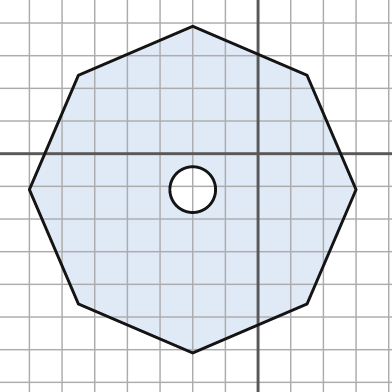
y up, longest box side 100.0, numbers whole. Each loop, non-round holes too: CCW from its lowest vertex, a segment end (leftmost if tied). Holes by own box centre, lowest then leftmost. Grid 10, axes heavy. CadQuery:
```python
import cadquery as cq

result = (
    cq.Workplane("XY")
    .moveTo(-20.0, -61.0)
    .lineTo(15.0, -46.0)
    .lineTo(30.0, -11.0)
    .lineTo(15.0, 24.0)
    .lineTo(-20.0, 39.0)
    .lineTo(-55.0, 24.0)
    .lineTo(-70.0, -11.0)
    .lineTo(-55.0, -46.0)
    .close()
    .moveTo(-20.0, -11.0)
    .circle(7.0)
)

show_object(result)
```